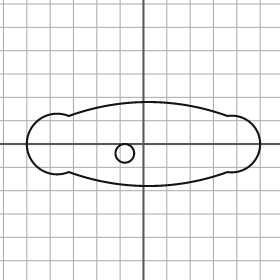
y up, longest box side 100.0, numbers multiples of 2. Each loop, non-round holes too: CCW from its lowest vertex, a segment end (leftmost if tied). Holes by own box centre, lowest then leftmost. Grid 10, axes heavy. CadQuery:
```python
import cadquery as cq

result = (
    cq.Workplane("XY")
    .moveTo(-32.0, -12.0)
    .threePointArc((2.0, -18.0), (36.0, -12.0))
    .threePointArc((50.0, 0.0), (36.0, 12.0))
    .threePointArc((2.0, 18.0), (-32.0, 12.0))
    .threePointArc((-50.0, 0.0), (-32.0, -12.0))
    .close()
    .moveTo(-8.0, -4.0)
    .circle(4.0)
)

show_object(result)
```